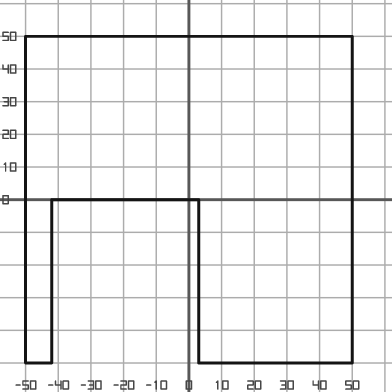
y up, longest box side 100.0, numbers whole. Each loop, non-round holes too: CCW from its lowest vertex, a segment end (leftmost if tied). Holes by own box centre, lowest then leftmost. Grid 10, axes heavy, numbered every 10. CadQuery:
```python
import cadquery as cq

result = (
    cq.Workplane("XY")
    .moveTo(-50.0, -50.0)
    .lineTo(-42.0, -50.0)
    .lineTo(-42.0, 0.0)
    .lineTo(3.0, 0.0)
    .lineTo(3.0, -50.0)
    .lineTo(50.0, -50.0)
    .lineTo(50.0, 50.0)
    .lineTo(-50.0, 50.0)
    .close()
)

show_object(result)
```